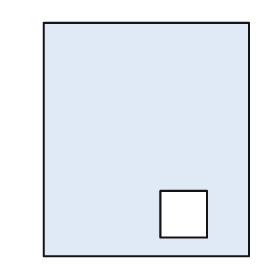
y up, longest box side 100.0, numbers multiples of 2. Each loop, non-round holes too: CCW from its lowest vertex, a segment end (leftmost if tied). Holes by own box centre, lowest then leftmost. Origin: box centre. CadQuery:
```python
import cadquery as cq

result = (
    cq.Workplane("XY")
    .moveTo(-44.0, -50.0)
    .lineTo(44.0, -50.0)
    .lineTo(44.0, 50.0)
    .lineTo(-44.0, 50.0)
    .close()
    .moveTo(6.0, -42.0)
    .lineTo(26.0, -42.0)
    .lineTo(26.0, -22.0)
    .lineTo(6.0, -22.0)
    .close()
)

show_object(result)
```